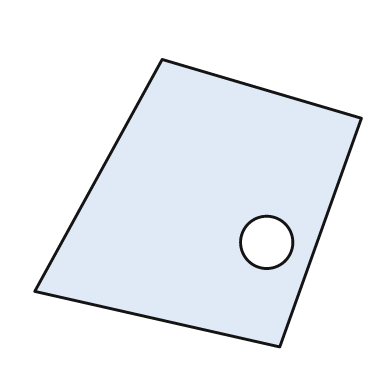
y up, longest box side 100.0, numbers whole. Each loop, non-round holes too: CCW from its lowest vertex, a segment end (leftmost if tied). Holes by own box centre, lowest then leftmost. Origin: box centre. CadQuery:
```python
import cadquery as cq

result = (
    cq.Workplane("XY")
    .moveTo(25.0, -44.0)
    .lineTo(50.0, 26.0)
    .lineTo(-11.0, 44.0)
    .lineTo(-50.0, -27.0)
    .close()
    .moveTo(21.0, -12.0)
    .circle(8.0)
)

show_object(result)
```